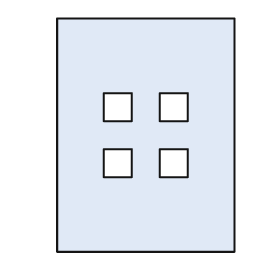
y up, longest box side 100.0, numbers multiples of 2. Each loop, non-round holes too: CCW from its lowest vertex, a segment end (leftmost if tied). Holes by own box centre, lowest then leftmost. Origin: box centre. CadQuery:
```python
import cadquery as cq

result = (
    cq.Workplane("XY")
    .moveTo(-38.0, -50.0)
    .lineTo(38.0, -50.0)
    .lineTo(38.0, 50.0)
    .lineTo(-38.0, 50.0)
    .close()
    .moveTo(-18.0, -18.0)
    .lineTo(-6.0, -18.0)
    .lineTo(-6.0, -6.0)
    .lineTo(-18.0, -6.0)
    .close()
    .moveTo(6.0, -18.0)
    .lineTo(18.0, -18.0)
    .lineTo(18.0, -6.0)
    .lineTo(6.0, -6.0)
    .close()
    .moveTo(-18.0, 6.0)
    .lineTo(-6.0, 6.0)
    .lineTo(-6.0, 18.0)
    .lineTo(-18.0, 18.0)
    .close()
    .moveTo(6.0, 6.0)
    .lineTo(18.0, 6.0)
    .lineTo(18.0, 18.0)
    .lineTo(6.0, 18.0)
    .close()
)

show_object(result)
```